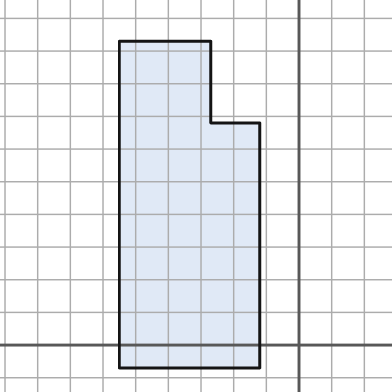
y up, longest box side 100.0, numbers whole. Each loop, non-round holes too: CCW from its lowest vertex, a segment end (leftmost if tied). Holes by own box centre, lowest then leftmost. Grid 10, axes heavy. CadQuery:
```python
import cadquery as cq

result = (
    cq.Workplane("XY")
    .moveTo(-55.0, -7.0)
    .lineTo(-12.0, -7.0)
    .lineTo(-12.0, 68.0)
    .lineTo(-27.0, 68.0)
    .lineTo(-27.0, 93.0)
    .lineTo(-55.0, 93.0)
    .close()
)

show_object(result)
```